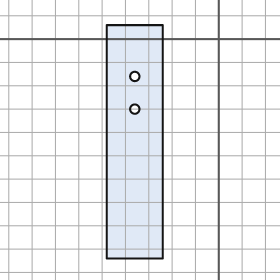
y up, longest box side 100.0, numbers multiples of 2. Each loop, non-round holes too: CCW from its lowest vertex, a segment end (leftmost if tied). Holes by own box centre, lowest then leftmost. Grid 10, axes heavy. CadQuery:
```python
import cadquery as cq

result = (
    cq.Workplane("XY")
    .moveTo(-48.0, -94.0)
    .lineTo(-24.0, -94.0)
    .lineTo(-24.0, 6.0)
    .lineTo(-48.0, 6.0)
    .close()
    .moveTo(-36.0, -30.0)
    .circle(2.0)
    .moveTo(-36.0, -16.0)
    .circle(2.0)
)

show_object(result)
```